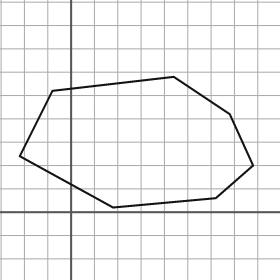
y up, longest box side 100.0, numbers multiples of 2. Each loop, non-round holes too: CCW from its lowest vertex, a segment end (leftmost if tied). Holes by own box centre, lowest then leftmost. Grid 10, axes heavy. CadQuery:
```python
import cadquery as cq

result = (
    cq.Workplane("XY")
    .moveTo(18.0, 2.0)
    .lineTo(62.0, 6.0)
    .lineTo(78.0, 20.0)
    .lineTo(68.0, 42.0)
    .lineTo(44.0, 58.0)
    .lineTo(-8.0, 52.0)
    .lineTo(-22.0, 24.0)
    .close()
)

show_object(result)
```